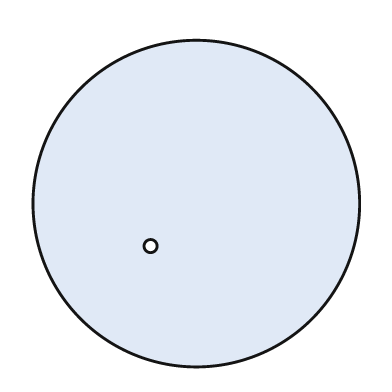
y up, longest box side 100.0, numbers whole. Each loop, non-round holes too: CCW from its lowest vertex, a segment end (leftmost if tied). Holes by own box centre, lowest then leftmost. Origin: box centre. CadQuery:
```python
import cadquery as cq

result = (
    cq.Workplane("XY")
    .moveTo(0.0, 0.0)
    .circle(50.0)
    .moveTo(-14.0, -13.0)
    .circle(2.0)
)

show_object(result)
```